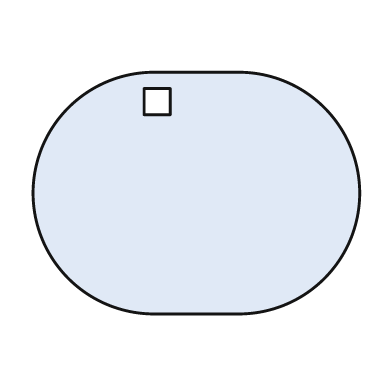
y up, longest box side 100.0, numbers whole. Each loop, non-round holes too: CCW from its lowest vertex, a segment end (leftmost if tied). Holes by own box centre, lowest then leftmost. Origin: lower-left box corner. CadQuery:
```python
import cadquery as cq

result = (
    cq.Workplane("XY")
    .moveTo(37.0, 0.0)
    .lineTo(63.0, 0.0)
    .threePointArc((100.0, 37.0), (63.0, 74.0))
    .lineTo(37.0, 74.0)
    .threePointArc((0.0, 37.0), (37.0, 0.0))
    .close()
    .moveTo(34.0, 61.0)
    .lineTo(42.0, 61.0)
    .lineTo(42.0, 69.0)
    .lineTo(34.0, 69.0)
    .close()
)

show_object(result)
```